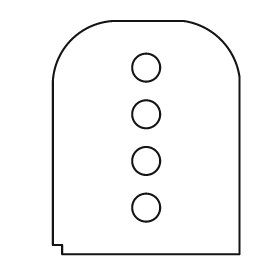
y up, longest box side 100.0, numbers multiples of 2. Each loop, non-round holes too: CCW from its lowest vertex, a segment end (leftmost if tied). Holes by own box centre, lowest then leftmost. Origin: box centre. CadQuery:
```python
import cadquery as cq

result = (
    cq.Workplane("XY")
    .moveTo(-36.0, -50.0)
    .lineTo(40.0, -50.0)
    .lineTo(40.0, 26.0)
    .threePointArc((32.0, 42.0), (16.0, 50.0))
    .lineTo(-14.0, 50.0)
    .threePointArc((-32.0, 42.0), (-40.0, 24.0))
    .lineTo(-40.0, -46.0)
    .lineTo(-36.0, -46.0)
    .close()
    .moveTo(0.0, -30.0)
    .circle(6.0)
    .moveTo(0.0, -10.0)
    .circle(6.0)
    .moveTo(0.0, 10.0)
    .circle(6.0)
    .moveTo(0.0, 30.0)
    .circle(6.0)
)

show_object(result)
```